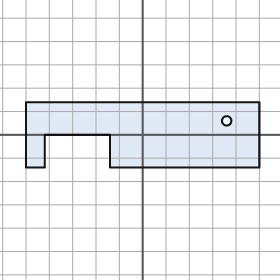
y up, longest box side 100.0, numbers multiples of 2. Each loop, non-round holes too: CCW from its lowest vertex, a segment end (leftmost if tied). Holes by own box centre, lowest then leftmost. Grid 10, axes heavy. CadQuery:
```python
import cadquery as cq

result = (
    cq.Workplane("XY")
    .moveTo(-50.0, -14.0)
    .lineTo(-42.0, -14.0)
    .lineTo(-42.0, 0.0)
    .lineTo(-14.0, 0.0)
    .lineTo(-14.0, -14.0)
    .lineTo(50.0, -14.0)
    .lineTo(50.0, 14.0)
    .lineTo(-50.0, 14.0)
    .close()
    .moveTo(36.0, 6.0)
    .circle(2.0)
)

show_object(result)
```